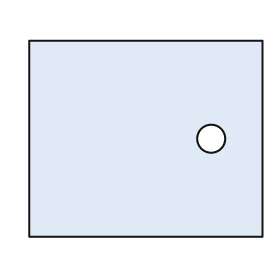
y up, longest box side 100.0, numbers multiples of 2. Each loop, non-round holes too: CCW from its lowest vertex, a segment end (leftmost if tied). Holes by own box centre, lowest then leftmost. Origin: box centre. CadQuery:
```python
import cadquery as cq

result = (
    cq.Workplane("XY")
    .moveTo(-50.0, -42.0)
    .lineTo(50.0, -42.0)
    .lineTo(50.0, 42.0)
    .lineTo(-50.0, 42.0)
    .close()
    .moveTo(28.0, 0.0)
    .circle(6.0)
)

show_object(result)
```